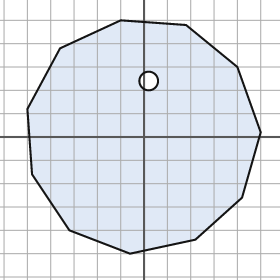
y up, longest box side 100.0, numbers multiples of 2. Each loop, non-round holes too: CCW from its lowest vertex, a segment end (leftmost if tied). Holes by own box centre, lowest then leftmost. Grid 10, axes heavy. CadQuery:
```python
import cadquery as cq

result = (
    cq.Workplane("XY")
    .moveTo(-6.0, -50.0)
    .lineTo(22.0, -44.0)
    .lineTo(42.0, -26.0)
    .lineTo(50.0, 2.0)
    .lineTo(40.0, 30.0)
    .lineTo(18.0, 48.0)
    .lineTo(-10.0, 50.0)
    .lineTo(-36.0, 38.0)
    .lineTo(-50.0, 12.0)
    .lineTo(-48.0, -16.0)
    .lineTo(-32.0, -40.0)
    .close()
    .moveTo(2.0, 24.0)
    .circle(4.0)
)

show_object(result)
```